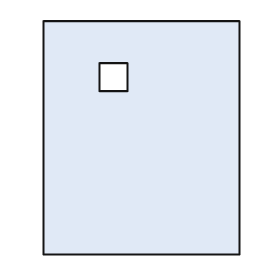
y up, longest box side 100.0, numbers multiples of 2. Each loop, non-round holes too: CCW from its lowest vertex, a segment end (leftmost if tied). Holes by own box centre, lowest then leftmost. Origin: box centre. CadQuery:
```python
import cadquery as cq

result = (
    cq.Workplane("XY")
    .moveTo(-42.0, -50.0)
    .lineTo(42.0, -50.0)
    .lineTo(42.0, 50.0)
    .lineTo(-42.0, 50.0)
    .close()
    .moveTo(-18.0, 20.0)
    .lineTo(-6.0, 20.0)
    .lineTo(-6.0, 32.0)
    .lineTo(-18.0, 32.0)
    .close()
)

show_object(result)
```